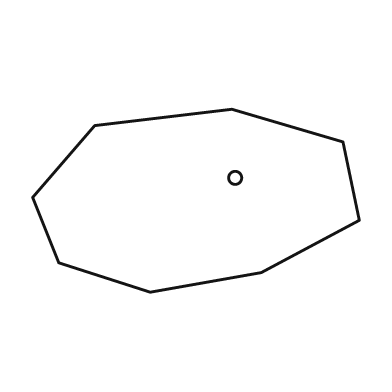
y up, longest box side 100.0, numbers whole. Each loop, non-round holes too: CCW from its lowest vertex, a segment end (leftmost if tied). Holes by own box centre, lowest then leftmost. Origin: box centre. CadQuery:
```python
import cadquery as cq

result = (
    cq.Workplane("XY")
    .moveTo(-14.0, -28.0)
    .lineTo(20.0, -22.0)
    .lineTo(50.0, -6.0)
    .lineTo(45.0, 18.0)
    .lineTo(11.0, 28.0)
    .lineTo(-31.0, 23.0)
    .lineTo(-50.0, 1.0)
    .lineTo(-42.0, -19.0)
    .close()
    .moveTo(12.0, 7.0)
    .circle(2.0)
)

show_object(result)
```